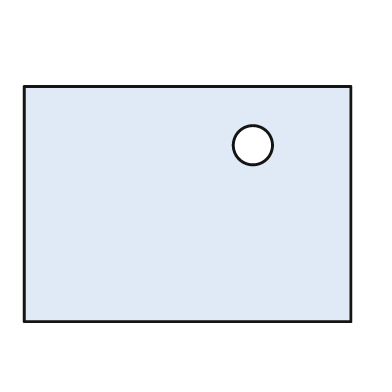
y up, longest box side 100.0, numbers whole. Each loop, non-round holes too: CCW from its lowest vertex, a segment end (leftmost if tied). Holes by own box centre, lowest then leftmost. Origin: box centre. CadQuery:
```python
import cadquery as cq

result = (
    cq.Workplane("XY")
    .moveTo(-50.0, -36.0)
    .lineTo(50.0, -36.0)
    .lineTo(50.0, 36.0)
    .lineTo(-50.0, 36.0)
    .close()
    .moveTo(20.0, 18.0)
    .circle(6.0)
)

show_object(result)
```